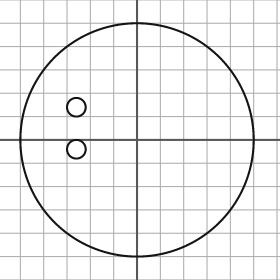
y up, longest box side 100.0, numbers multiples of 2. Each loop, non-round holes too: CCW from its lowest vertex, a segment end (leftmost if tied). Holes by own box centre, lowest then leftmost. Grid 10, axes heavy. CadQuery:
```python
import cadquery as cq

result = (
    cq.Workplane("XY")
    .moveTo(0.0, 0.0)
    .circle(50.0)
    .moveTo(-26.0, -4.0)
    .circle(4.0)
    .moveTo(-26.0, 14.0)
    .circle(4.0)
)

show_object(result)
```